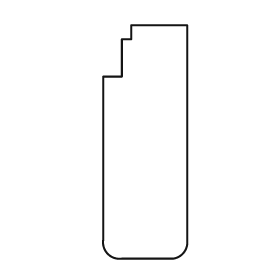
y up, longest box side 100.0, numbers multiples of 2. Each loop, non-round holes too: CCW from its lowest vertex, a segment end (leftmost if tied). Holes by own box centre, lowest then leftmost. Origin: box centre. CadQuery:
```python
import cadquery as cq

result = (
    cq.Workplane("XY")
    .moveTo(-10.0, -50.0)
    .lineTo(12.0, -50.0)
    .threePointArc((16.0, -48.0), (18.0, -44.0))
    .lineTo(18.0, 50.0)
    .lineTo(-6.0, 50.0)
    .lineTo(-6.0, 44.0)
    .lineTo(-10.0, 44.0)
    .lineTo(-10.0, 28.0)
    .lineTo(-18.0, 28.0)
    .lineTo(-18.0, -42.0)
    .threePointArc((-16.0, -48.0), (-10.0, -50.0))
    .close()
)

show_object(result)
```